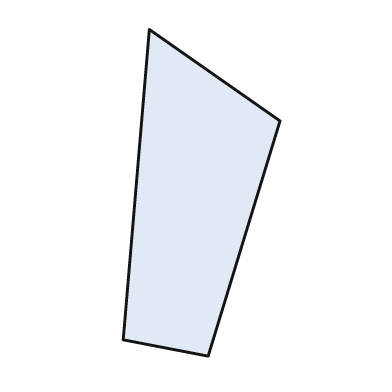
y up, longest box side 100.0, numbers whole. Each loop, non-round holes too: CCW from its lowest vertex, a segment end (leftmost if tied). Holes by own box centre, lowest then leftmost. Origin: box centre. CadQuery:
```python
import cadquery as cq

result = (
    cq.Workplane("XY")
    .moveTo(2.0, -50.0)
    .lineTo(24.0, 22.0)
    .lineTo(-16.0, 50.0)
    .lineTo(-24.0, -45.0)
    .close()
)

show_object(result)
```